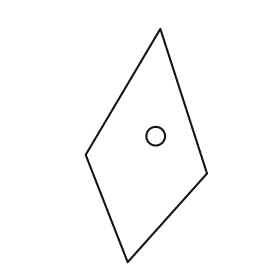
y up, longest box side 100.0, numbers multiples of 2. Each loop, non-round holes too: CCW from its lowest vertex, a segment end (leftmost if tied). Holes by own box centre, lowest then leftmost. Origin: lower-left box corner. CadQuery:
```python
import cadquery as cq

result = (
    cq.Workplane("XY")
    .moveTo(18.0, 0.0)
    .lineTo(52.0, 38.0)
    .lineTo(32.0, 100.0)
    .lineTo(0.0, 46.0)
    .close()
    .moveTo(30.0, 54.0)
    .circle(4.0)
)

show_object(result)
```